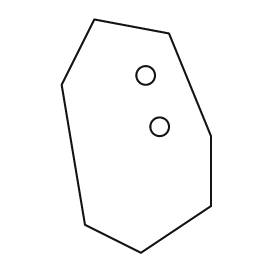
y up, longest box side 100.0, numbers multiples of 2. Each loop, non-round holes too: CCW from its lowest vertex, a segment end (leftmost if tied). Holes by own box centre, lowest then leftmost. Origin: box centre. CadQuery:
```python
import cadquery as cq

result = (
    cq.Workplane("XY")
    .moveTo(2.0, -50.0)
    .lineTo(32.0, -30.0)
    .lineTo(32.0, 0.0)
    .lineTo(14.0, 44.0)
    .lineTo(-18.0, 50.0)
    .lineTo(-32.0, 22.0)
    .lineTo(-22.0, -38.0)
    .close()
    .moveTo(10.0, 4.0)
    .circle(4.0)
    .moveTo(4.0, 26.0)
    .circle(4.0)
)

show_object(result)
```